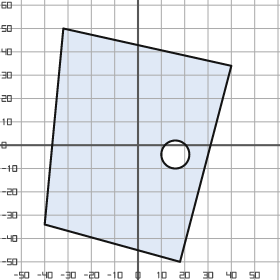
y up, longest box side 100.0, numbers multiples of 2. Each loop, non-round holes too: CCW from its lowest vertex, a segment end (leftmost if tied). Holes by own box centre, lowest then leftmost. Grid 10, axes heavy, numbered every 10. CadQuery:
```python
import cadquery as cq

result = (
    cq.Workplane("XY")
    .moveTo(18.0, -50.0)
    .lineTo(40.0, 34.0)
    .lineTo(-32.0, 50.0)
    .lineTo(-40.0, -34.0)
    .close()
    .moveTo(16.0, -4.0)
    .circle(6.0)
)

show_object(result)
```